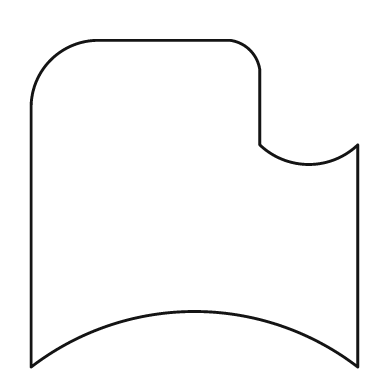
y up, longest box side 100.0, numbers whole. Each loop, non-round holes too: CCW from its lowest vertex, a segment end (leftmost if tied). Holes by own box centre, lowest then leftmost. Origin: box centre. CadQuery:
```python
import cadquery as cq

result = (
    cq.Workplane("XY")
    .moveTo(-50.0, -50.0)
    .threePointArc((0.0, -33.0), (50.0, -50.0))
    .lineTo(50.0, 18.0)
    .threePointArc((35.0, 12.0), (20.0, 18.0))
    .lineTo(20.0, 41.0)
    .threePointArc((17.0, 47.0), (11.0, 50.0))
    .lineTo(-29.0, 50.0)
    .threePointArc((-44.0, 44.0), (-50.0, 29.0))
    .close()
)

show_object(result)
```